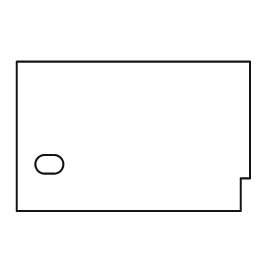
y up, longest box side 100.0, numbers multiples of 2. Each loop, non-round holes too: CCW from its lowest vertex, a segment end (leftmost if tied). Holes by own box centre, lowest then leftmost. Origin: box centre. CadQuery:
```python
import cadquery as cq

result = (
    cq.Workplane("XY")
    .moveTo(-50.0, -32.0)
    .lineTo(46.0, -32.0)
    .lineTo(46.0, -18.0)
    .lineTo(50.0, -18.0)
    .lineTo(50.0, 32.0)
    .lineTo(-50.0, 32.0)
    .close()
    .moveTo(-38.0, -16.0)
    .lineTo(-34.0, -16.0)
    .threePointArc((-30.0, -12.0), (-34.0, -8.0))
    .lineTo(-38.0, -8.0)
    .threePointArc((-42.0, -12.0), (-38.0, -16.0))
    .close()
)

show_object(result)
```